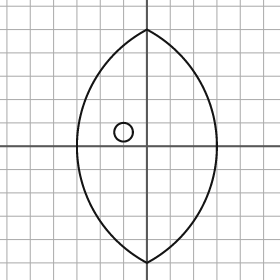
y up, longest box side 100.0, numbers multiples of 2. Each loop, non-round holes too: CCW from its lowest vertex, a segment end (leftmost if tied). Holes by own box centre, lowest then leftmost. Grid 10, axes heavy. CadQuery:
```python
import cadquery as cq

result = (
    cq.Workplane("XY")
    .moveTo(0.0, -50.0)
    .threePointArc((30.0, 0.0), (0.0, 50.0))
    .threePointArc((-30.0, 0.0), (0.0, -50.0))
    .close()
    .moveTo(-10.0, 6.0)
    .circle(4.0)
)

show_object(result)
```